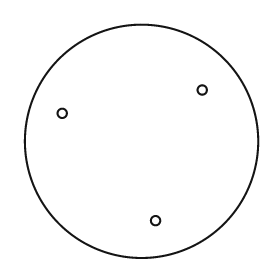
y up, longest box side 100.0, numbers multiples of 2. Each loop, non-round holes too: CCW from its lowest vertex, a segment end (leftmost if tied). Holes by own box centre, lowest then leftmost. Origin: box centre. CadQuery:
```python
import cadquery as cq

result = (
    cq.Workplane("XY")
    .moveTo(0.0, 0.0)
    .circle(50.0)
    .moveTo(6.0, -34.0)
    .circle(2.0)
    .moveTo(-34.0, 12.0)
    .circle(2.0)
    .moveTo(26.0, 22.0)
    .circle(2.0)
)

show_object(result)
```